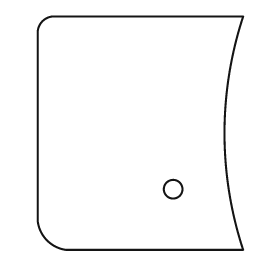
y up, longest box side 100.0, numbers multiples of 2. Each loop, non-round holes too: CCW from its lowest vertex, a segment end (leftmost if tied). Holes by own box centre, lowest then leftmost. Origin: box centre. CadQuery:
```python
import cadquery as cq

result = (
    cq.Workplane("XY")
    .moveTo(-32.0, -50.0)
    .lineTo(44.0, -50.0)
    .threePointArc((36.0, 0.0), (44.0, 50.0))
    .lineTo(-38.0, 50.0)
    .threePointArc((-42.0, 48.0), (-44.0, 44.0))
    .lineTo(-44.0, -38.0)
    .threePointArc((-40.0, -46.0), (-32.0, -50.0))
    .close()
    .moveTo(14.0, -24.0)
    .circle(4.0)
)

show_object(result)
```